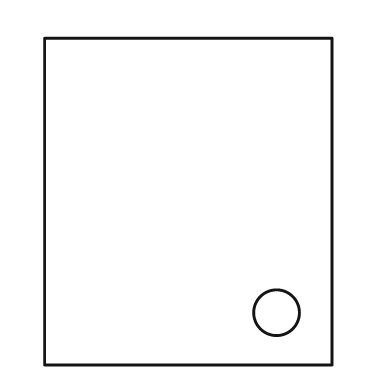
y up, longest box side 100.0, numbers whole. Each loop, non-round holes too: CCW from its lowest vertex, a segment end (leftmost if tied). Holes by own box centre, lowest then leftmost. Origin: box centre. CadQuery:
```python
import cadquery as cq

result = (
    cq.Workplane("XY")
    .moveTo(-44.0, -50.0)
    .lineTo(44.0, -50.0)
    .lineTo(44.0, 50.0)
    .lineTo(-44.0, 50.0)
    .close()
    .moveTo(27.0, -34.0)
    .circle(7.0)
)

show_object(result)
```